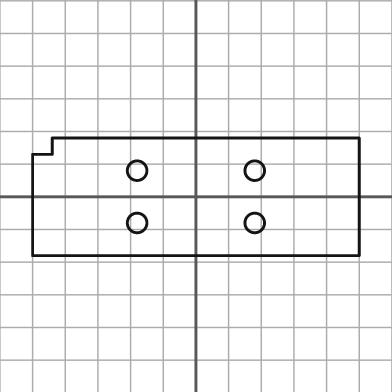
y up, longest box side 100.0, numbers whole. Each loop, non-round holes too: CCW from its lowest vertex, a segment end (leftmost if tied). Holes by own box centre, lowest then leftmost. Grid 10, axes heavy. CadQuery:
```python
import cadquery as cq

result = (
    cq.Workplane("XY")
    .moveTo(-50.0, -18.0)
    .lineTo(50.0, -18.0)
    .lineTo(50.0, 18.0)
    .lineTo(-44.0, 18.0)
    .lineTo(-44.0, 13.0)
    .lineTo(-50.0, 13.0)
    .close()
    .moveTo(-18.0, -8.0)
    .circle(3.0)
    .moveTo(18.0, -8.0)
    .circle(3.0)
    .moveTo(-18.0, 8.0)
    .circle(3.0)
    .moveTo(18.0, 8.0)
    .circle(3.0)
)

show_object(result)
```